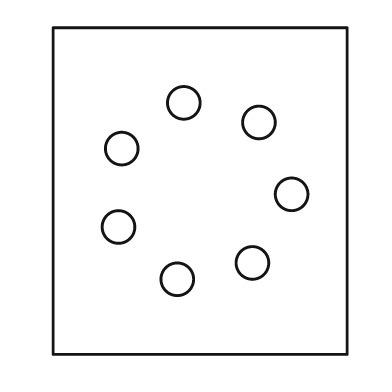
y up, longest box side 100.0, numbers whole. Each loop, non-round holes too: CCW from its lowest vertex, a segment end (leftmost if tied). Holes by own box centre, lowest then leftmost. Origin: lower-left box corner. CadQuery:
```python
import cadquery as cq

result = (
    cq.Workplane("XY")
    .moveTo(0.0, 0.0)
    .lineTo(90.0, 0.0)
    .lineTo(90.0, 100.0)
    .lineTo(0.0, 100.0)
    .close()
    .moveTo(38.0, 23.0)
    .circle(5.0)
    .moveTo(61.0, 28.0)
    .circle(5.0)
    .moveTo(20.0, 39.0)
    .circle(5.0)
    .moveTo(73.0, 49.0)
    .circle(5.0)
    .moveTo(21.0, 63.0)
    .circle(5.0)
    .moveTo(63.0, 71.0)
    .circle(5.0)
    .moveTo(40.0, 77.0)
    .circle(5.0)
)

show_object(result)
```